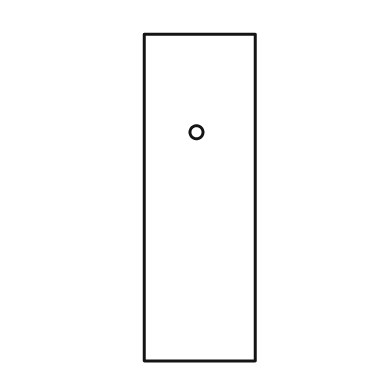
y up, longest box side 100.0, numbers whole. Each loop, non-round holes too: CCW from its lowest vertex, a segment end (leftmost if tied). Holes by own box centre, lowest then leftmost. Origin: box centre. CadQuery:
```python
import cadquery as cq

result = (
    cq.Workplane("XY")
    .moveTo(-17.0, -50.0)
    .lineTo(17.0, -50.0)
    .lineTo(17.0, 50.0)
    .lineTo(-17.0, 50.0)
    .close()
    .moveTo(-1.0, 20.0)
    .circle(2.0)
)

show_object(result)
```